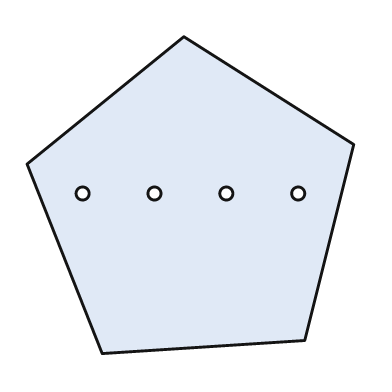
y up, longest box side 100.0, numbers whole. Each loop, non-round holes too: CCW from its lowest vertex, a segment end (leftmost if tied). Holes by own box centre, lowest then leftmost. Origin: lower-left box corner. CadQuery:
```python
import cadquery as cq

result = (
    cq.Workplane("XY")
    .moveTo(23.0, 0.0)
    .lineTo(85.0, 4.0)
    .lineTo(100.0, 64.0)
    .lineTo(48.0, 97.0)
    .lineTo(0.0, 58.0)
    .close()
    .moveTo(17.0, 49.0)
    .circle(2.0)
    .moveTo(39.0, 49.0)
    .circle(2.0)
    .moveTo(61.0, 49.0)
    .circle(2.0)
    .moveTo(83.0, 49.0)
    .circle(2.0)
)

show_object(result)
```